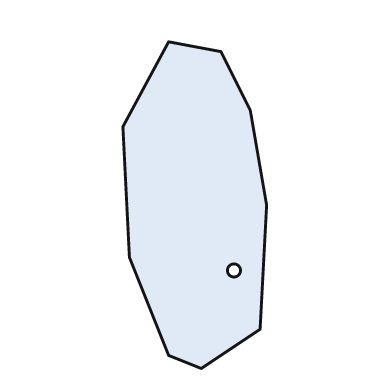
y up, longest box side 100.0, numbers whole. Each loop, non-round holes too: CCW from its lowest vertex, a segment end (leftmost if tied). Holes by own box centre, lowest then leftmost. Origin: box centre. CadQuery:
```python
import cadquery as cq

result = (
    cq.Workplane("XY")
    .moveTo(2.0, -50.0)
    .lineTo(20.0, -38.0)
    .lineTo(22.0, 0.0)
    .lineTo(17.0, 29.0)
    .lineTo(8.0, 47.0)
    .lineTo(-8.0, 50.0)
    .lineTo(-22.0, 24.0)
    .lineTo(-20.0, -16.0)
    .lineTo(-8.0, -46.0)
    .close()
    .moveTo(12.0, -20.0)
    .circle(2.0)
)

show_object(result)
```